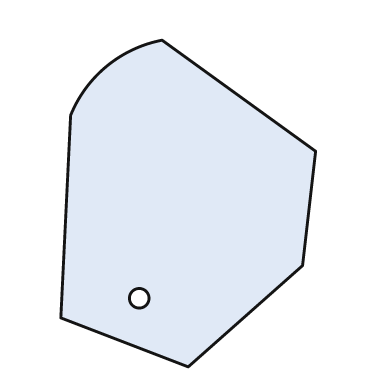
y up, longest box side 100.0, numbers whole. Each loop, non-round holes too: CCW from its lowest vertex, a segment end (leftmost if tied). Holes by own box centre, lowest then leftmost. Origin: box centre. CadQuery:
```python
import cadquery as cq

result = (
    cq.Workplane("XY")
    .moveTo(0.0, -50.0)
    .lineTo(35.0, -19.0)
    .lineTo(39.0, 16.0)
    .lineTo(-8.0, 50.0)
    .threePointArc((-25.0, 42.0), (-36.0, 27.0))
    .lineTo(-39.0, -35.0)
    .close()
    .moveTo(-15.0, -29.0)
    .circle(3.0)
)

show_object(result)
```